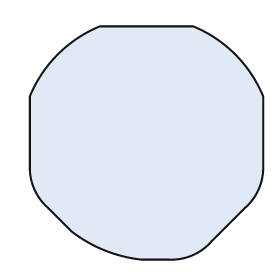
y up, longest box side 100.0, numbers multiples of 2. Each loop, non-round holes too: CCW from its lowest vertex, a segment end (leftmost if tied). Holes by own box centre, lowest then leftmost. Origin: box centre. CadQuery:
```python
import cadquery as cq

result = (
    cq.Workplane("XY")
    .moveTo(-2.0, -50.0)
    .lineTo(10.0, -50.0)
    .threePointArc((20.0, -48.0), (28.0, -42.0))
    .lineTo(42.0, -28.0)
    .threePointArc((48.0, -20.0), (50.0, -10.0))
    .lineTo(50.0, 20.0)
    .threePointArc((38.0, 38.0), (20.0, 50.0))
    .lineTo(-20.0, 50.0)
    .threePointArc((-38.0, 38.0), (-50.0, 20.0))
    .lineTo(-50.0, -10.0)
    .threePointArc((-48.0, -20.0), (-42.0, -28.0))
    .lineTo(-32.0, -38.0)
    .threePointArc((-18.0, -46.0), (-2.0, -50.0))
    .close()
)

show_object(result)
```